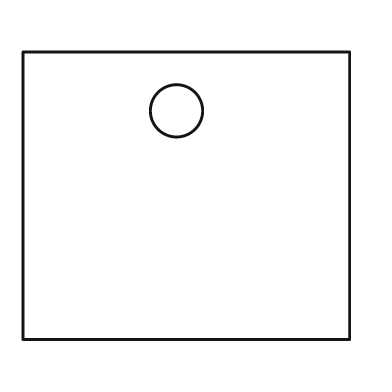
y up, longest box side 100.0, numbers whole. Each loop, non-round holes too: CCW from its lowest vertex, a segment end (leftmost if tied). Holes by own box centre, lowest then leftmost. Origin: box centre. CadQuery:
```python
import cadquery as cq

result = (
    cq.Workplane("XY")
    .moveTo(-50.0, -44.0)
    .lineTo(50.0, -44.0)
    .lineTo(50.0, 44.0)
    .lineTo(-50.0, 44.0)
    .close()
    .moveTo(-3.0, 26.0)
    .circle(8.0)
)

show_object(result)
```